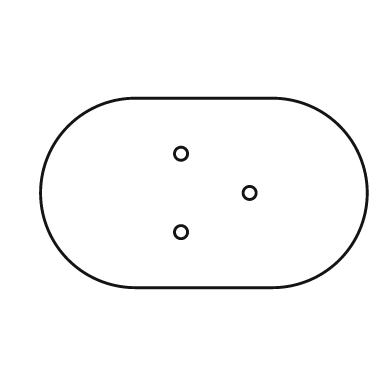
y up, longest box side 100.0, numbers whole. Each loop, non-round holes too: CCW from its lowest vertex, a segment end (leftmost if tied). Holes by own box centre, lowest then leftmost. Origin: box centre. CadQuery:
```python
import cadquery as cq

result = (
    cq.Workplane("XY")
    .moveTo(-21.0, -29.0)
    .lineTo(21.0, -29.0)
    .threePointArc((50.0, 0.0), (21.0, 29.0))
    .lineTo(-21.0, 29.0)
    .threePointArc((-50.0, 0.0), (-21.0, -29.0))
    .close()
    .moveTo(-7.0, -12.0)
    .circle(2.0)
    .moveTo(14.0, 0.0)
    .circle(2.0)
    .moveTo(-7.0, 12.0)
    .circle(2.0)
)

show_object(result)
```